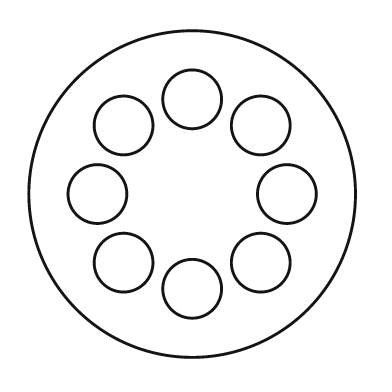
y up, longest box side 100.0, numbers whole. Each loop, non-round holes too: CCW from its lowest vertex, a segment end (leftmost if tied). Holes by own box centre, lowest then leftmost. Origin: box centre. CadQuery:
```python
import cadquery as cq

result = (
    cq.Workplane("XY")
    .moveTo(0.0, 0.0)
    .circle(50.0)
    .moveTo(0.0, -29.0)
    .circle(9.0)
    .moveTo(-21.0, -21.0)
    .circle(9.0)
    .moveTo(21.0, -21.0)
    .circle(9.0)
    .moveTo(-29.0, 0.0)
    .circle(9.0)
    .moveTo(29.0, 0.0)
    .circle(9.0)
    .moveTo(-21.0, 21.0)
    .circle(9.0)
    .moveTo(21.0, 21.0)
    .circle(9.0)
    .moveTo(0.0, 29.0)
    .circle(9.0)
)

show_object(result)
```